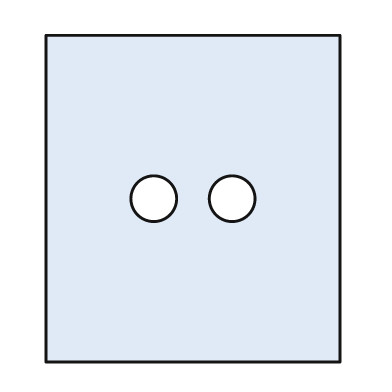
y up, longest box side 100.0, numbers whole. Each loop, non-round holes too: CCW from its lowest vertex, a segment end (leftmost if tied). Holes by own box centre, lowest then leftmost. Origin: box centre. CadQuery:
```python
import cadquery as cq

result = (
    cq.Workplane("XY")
    .moveTo(-45.0, -50.0)
    .lineTo(45.0, -50.0)
    .lineTo(45.0, 50.0)
    .lineTo(-45.0, 50.0)
    .close()
    .moveTo(-12.0, 0.0)
    .circle(7.0)
    .moveTo(12.0, 0.0)
    .circle(7.0)
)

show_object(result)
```